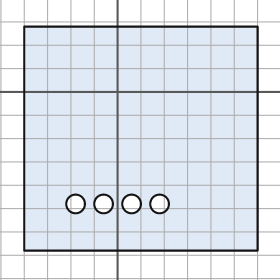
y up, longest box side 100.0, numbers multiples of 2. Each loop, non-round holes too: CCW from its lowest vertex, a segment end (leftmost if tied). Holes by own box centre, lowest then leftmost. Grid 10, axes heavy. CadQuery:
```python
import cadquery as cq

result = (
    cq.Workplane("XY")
    .moveTo(-40.0, -68.0)
    .lineTo(60.0, -68.0)
    .lineTo(60.0, 28.0)
    .lineTo(-40.0, 28.0)
    .close()
    .moveTo(-18.0, -48.0)
    .circle(4.0)
    .moveTo(-6.0, -48.0)
    .circle(4.0)
    .moveTo(6.0, -48.0)
    .circle(4.0)
    .moveTo(18.0, -48.0)
    .circle(4.0)
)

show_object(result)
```